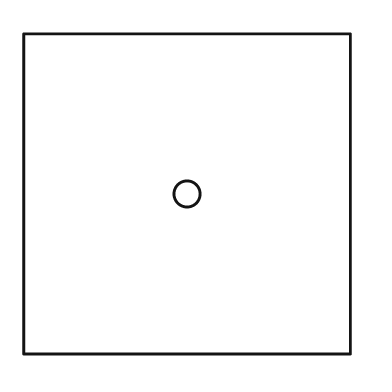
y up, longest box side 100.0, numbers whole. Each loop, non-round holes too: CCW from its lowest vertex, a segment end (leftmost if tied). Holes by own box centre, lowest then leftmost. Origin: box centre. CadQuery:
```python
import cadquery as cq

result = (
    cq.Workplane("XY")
    .moveTo(-50.0, -49.0)
    .lineTo(50.0, -49.0)
    .lineTo(50.0, 49.0)
    .lineTo(-50.0, 49.0)
    .close()
    .moveTo(0.0, 0.0)
    .circle(4.0)
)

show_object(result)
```